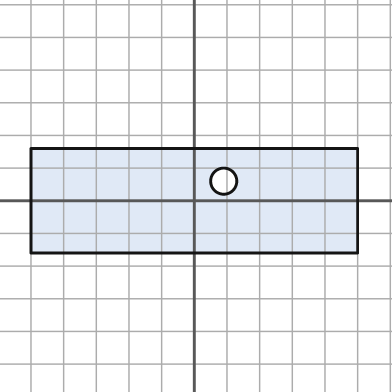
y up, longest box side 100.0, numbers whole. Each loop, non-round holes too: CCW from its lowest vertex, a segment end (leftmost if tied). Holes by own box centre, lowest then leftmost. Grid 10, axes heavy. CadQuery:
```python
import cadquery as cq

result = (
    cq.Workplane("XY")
    .moveTo(-50.0, -16.0)
    .lineTo(50.0, -16.0)
    .lineTo(50.0, 16.0)
    .lineTo(-50.0, 16.0)
    .close()
    .moveTo(9.0, 6.0)
    .circle(4.0)
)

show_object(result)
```